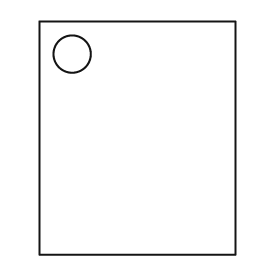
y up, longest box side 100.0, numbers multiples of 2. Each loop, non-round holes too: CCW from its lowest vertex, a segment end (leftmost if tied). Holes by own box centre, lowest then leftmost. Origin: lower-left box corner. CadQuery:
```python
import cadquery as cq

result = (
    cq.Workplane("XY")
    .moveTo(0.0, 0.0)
    .lineTo(84.0, 0.0)
    .lineTo(84.0, 100.0)
    .lineTo(0.0, 100.0)
    .close()
    .moveTo(14.0, 86.0)
    .circle(8.0)
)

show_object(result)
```